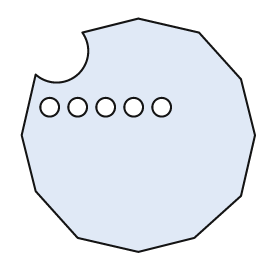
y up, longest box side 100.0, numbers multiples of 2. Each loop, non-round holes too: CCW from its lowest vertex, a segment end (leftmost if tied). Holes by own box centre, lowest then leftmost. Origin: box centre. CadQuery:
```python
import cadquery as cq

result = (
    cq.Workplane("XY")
    .moveTo(0.0, -50.0)
    .lineTo(24.0, -44.0)
    .lineTo(44.0, -26.0)
    .lineTo(50.0, 0.0)
    .lineTo(44.0, 24.0)
    .lineTo(26.0, 44.0)
    .lineTo(0.0, 50.0)
    .lineTo(-24.0, 44.0)
    .threePointArc((-26.0, 26.0), (-44.0, 26.0))
    .lineTo(-50.0, 0.0)
    .lineTo(-44.0, -24.0)
    .lineTo(-26.0, -44.0)
    .close()
    .moveTo(-38.0, 12.0)
    .circle(4.0)
    .moveTo(-26.0, 12.0)
    .circle(4.0)
    .moveTo(-14.0, 12.0)
    .circle(4.0)
    .moveTo(-2.0, 12.0)
    .circle(4.0)
    .moveTo(10.0, 12.0)
    .circle(4.0)
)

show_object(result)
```